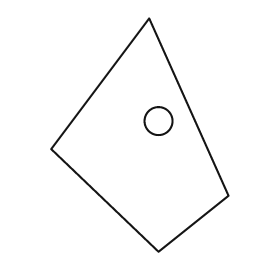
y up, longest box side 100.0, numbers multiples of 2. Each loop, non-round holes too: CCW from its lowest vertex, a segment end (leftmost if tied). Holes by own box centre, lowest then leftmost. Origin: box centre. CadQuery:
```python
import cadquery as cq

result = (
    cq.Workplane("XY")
    .moveTo(8.0, -50.0)
    .lineTo(38.0, -26.0)
    .lineTo(4.0, 50.0)
    .lineTo(-38.0, -6.0)
    .close()
    .moveTo(8.0, 6.0)
    .circle(6.0)
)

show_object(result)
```